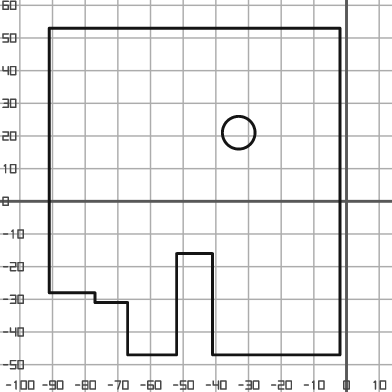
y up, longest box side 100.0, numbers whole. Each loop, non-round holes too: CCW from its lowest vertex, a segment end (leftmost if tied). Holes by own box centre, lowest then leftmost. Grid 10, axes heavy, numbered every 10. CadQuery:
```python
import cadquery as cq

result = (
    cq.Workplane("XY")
    .moveTo(-67.0, -47.0)
    .lineTo(-52.0, -47.0)
    .lineTo(-52.0, -16.0)
    .lineTo(-41.0, -16.0)
    .lineTo(-41.0, -47.0)
    .lineTo(-2.0, -47.0)
    .lineTo(-2.0, 53.0)
    .lineTo(-91.0, 53.0)
    .lineTo(-91.0, -28.0)
    .lineTo(-77.0, -28.0)
    .lineTo(-77.0, -31.0)
    .lineTo(-67.0, -31.0)
    .close()
    .moveTo(-33.0, 21.0)
    .circle(5.0)
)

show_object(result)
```